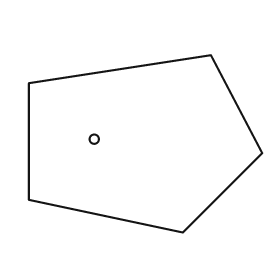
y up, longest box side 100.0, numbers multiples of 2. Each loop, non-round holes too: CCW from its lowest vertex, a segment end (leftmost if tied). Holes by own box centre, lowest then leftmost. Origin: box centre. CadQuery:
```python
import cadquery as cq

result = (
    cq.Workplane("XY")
    .moveTo(16.0, -38.0)
    .lineTo(50.0, -4.0)
    .lineTo(28.0, 38.0)
    .lineTo(-50.0, 26.0)
    .lineTo(-50.0, -24.0)
    .close()
    .moveTo(-22.0, 2.0)
    .circle(2.0)
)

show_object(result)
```